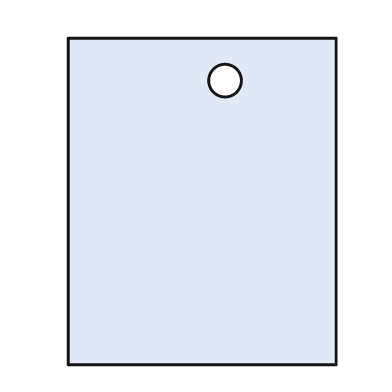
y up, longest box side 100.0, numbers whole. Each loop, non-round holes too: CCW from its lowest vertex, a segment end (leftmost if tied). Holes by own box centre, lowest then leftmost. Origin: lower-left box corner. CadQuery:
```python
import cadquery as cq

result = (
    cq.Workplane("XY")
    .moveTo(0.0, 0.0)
    .lineTo(82.0, 0.0)
    .lineTo(82.0, 100.0)
    .lineTo(0.0, 100.0)
    .close()
    .moveTo(48.0, 87.0)
    .circle(5.0)
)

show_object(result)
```